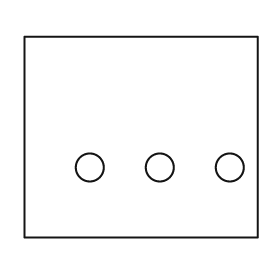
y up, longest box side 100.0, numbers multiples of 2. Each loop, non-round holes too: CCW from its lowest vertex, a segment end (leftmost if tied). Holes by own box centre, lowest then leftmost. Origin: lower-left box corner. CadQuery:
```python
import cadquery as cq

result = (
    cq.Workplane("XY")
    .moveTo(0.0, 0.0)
    .lineTo(100.0, 0.0)
    .lineTo(100.0, 86.0)
    .lineTo(0.0, 86.0)
    .close()
    .moveTo(28.0, 30.0)
    .circle(6.0)
    .moveTo(58.0, 30.0)
    .circle(6.0)
    .moveTo(88.0, 30.0)
    .circle(6.0)
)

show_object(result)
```